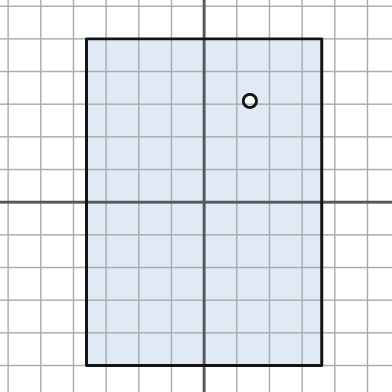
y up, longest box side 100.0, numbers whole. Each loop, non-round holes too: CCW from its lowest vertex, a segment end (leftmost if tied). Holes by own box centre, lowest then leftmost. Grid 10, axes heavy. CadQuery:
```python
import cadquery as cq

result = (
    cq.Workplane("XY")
    .moveTo(-36.0, -50.0)
    .lineTo(36.0, -50.0)
    .lineTo(36.0, 50.0)
    .lineTo(-36.0, 50.0)
    .close()
    .moveTo(14.0, 31.0)
    .circle(2.0)
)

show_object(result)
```